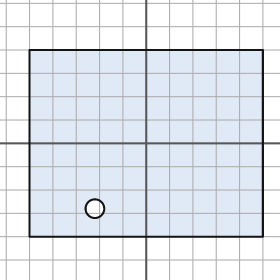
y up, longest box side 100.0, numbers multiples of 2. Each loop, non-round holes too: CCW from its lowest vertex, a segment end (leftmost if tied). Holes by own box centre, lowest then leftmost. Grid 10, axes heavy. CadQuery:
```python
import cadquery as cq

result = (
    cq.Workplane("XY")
    .moveTo(-50.0, -40.0)
    .lineTo(50.0, -40.0)
    .lineTo(50.0, 40.0)
    .lineTo(-50.0, 40.0)
    .close()
    .moveTo(-22.0, -28.0)
    .circle(4.0)
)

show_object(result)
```